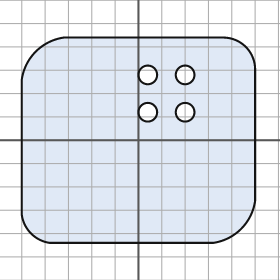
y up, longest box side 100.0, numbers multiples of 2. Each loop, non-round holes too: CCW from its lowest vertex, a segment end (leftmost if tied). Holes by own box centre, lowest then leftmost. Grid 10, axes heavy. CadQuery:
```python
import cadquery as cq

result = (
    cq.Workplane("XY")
    .moveTo(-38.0, -44.0)
    .lineTo(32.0, -44.0)
    .threePointArc((44.0, -38.0), (50.0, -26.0))
    .lineTo(50.0, 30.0)
    .threePointArc((46.0, 40.0), (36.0, 44.0))
    .lineTo(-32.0, 44.0)
    .threePointArc((-44.0, 38.0), (-50.0, 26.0))
    .lineTo(-50.0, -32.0)
    .threePointArc((-46.0, -40.0), (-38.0, -44.0))
    .close()
    .moveTo(4.0, 12.0)
    .circle(4.0)
    .moveTo(20.0, 12.0)
    .circle(4.0)
    .moveTo(4.0, 28.0)
    .circle(4.0)
    .moveTo(20.0, 28.0)
    .circle(4.0)
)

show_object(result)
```